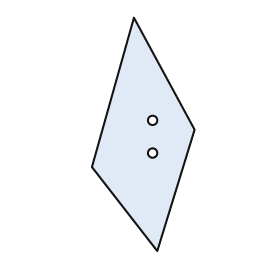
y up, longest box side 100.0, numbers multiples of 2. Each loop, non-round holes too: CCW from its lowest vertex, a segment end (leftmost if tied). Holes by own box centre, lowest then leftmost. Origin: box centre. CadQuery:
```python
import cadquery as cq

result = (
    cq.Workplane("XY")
    .moveTo(6.0, -50.0)
    .lineTo(22.0, 2.0)
    .lineTo(-4.0, 50.0)
    .lineTo(-22.0, -14.0)
    .close()
    .moveTo(4.0, -8.0)
    .circle(2.0)
    .moveTo(4.0, 6.0)
    .circle(2.0)
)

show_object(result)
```